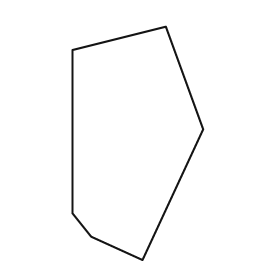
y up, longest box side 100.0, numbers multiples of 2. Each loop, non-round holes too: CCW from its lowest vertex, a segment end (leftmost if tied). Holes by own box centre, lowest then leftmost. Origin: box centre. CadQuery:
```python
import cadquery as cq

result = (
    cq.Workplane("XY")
    .moveTo(2.0, -50.0)
    .lineTo(28.0, 6.0)
    .lineTo(12.0, 50.0)
    .lineTo(-28.0, 40.0)
    .lineTo(-28.0, -30.0)
    .lineTo(-20.0, -40.0)
    .close()
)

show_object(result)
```